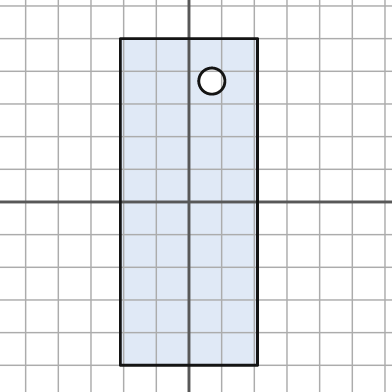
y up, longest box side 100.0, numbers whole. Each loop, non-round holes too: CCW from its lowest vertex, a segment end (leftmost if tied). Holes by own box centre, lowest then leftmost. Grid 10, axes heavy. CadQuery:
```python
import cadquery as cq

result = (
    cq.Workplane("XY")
    .moveTo(-21.0, -50.0)
    .lineTo(21.0, -50.0)
    .lineTo(21.0, 50.0)
    .lineTo(-21.0, 50.0)
    .close()
    .moveTo(7.0, 37.0)
    .circle(4.0)
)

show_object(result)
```